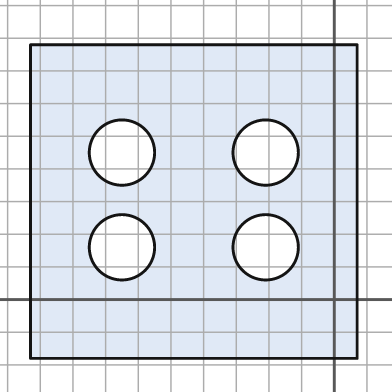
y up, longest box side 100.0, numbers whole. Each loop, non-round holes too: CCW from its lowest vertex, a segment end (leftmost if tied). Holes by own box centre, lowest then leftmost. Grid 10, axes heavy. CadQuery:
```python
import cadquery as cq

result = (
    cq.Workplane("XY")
    .moveTo(-93.0, -18.0)
    .lineTo(7.0, -18.0)
    .lineTo(7.0, 78.0)
    .lineTo(-93.0, 78.0)
    .close()
    .moveTo(-65.0, 16.0)
    .circle(10.0)
    .moveTo(-21.0, 16.0)
    .circle(10.0)
    .moveTo(-65.0, 45.0)
    .circle(10.0)
    .moveTo(-21.0, 45.0)
    .circle(10.0)
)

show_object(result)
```